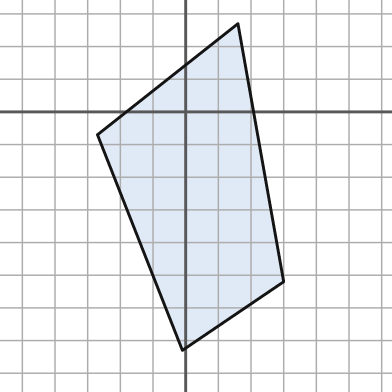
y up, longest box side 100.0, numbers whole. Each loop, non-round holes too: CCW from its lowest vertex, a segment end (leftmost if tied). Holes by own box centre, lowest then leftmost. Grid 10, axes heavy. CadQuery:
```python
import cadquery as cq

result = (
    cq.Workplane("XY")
    .moveTo(-1.0, -73.0)
    .lineTo(30.0, -52.0)
    .lineTo(16.0, 27.0)
    .lineTo(-27.0, -7.0)
    .close()
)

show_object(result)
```